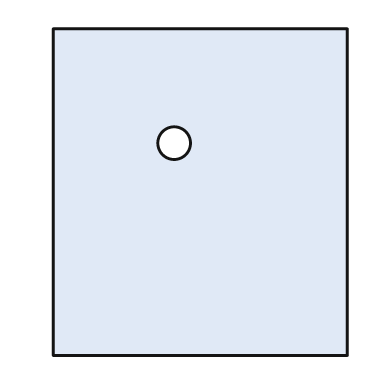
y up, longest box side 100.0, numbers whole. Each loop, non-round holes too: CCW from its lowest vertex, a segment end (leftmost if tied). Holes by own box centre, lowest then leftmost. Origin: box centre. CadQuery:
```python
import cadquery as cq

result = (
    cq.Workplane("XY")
    .moveTo(-45.0, -50.0)
    .lineTo(45.0, -50.0)
    .lineTo(45.0, 50.0)
    .lineTo(-45.0, 50.0)
    .close()
    .moveTo(-8.0, 15.0)
    .circle(5.0)
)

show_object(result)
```